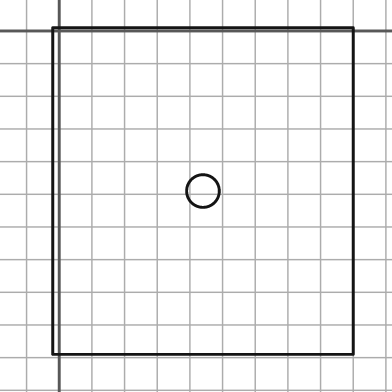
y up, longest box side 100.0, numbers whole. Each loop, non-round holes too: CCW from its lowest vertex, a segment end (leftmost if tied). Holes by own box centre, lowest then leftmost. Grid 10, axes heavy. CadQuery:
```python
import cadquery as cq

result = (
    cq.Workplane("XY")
    .moveTo(-2.0, -99.0)
    .lineTo(90.0, -99.0)
    .lineTo(90.0, 1.0)
    .lineTo(-2.0, 1.0)
    .close()
    .moveTo(44.0, -49.0)
    .circle(5.0)
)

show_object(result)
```